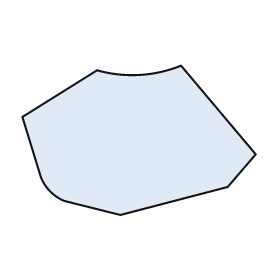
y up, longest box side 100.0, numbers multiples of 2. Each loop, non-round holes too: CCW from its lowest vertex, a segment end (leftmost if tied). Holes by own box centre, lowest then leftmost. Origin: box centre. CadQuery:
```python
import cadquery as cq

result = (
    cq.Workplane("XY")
    .moveTo(-8.0, -32.0)
    .lineTo(38.0, -20.0)
    .lineTo(50.0, -6.0)
    .lineTo(18.0, 32.0)
    .threePointArc((0.0, 28.0), (-18.0, 30.0))
    .lineTo(-50.0, 10.0)
    .lineTo(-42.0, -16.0)
    .threePointArc((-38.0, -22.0), (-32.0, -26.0))
    .close()
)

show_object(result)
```